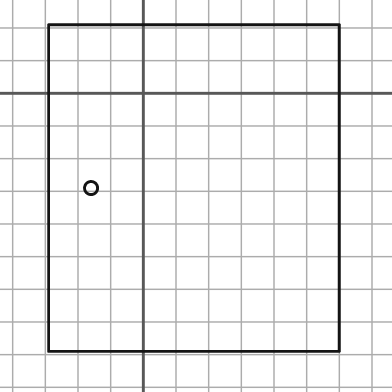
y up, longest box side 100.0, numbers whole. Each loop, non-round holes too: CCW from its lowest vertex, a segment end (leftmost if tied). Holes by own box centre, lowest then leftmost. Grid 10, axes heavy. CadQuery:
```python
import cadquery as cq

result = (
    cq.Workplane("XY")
    .moveTo(-29.0, -79.0)
    .lineTo(60.0, -79.0)
    .lineTo(60.0, 21.0)
    .lineTo(-29.0, 21.0)
    .close()
    .moveTo(-16.0, -29.0)
    .circle(2.0)
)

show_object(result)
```